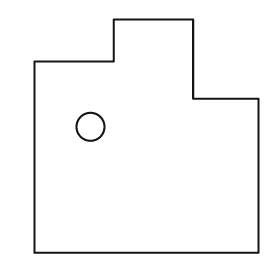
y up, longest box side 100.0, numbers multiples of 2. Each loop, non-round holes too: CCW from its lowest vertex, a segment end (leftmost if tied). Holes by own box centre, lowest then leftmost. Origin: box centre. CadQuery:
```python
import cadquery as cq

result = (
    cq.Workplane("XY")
    .moveTo(-48.0, -50.0)
    .lineTo(48.0, -50.0)
    .lineTo(48.0, 16.0)
    .lineTo(20.0, 16.0)
    .lineTo(20.0, 50.0)
    .lineTo(-14.0, 50.0)
    .lineTo(-14.0, 32.0)
    .lineTo(-48.0, 32.0)
    .close()
    .moveTo(-24.0, 4.0)
    .circle(6.0)
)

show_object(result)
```